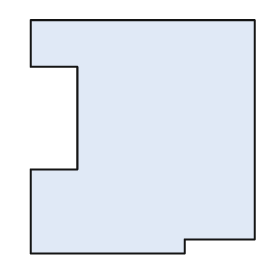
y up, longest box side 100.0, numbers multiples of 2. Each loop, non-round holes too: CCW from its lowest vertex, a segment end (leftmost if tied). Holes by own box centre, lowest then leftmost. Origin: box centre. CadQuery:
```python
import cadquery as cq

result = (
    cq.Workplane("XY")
    .moveTo(-48.0, -50.0)
    .lineTo(18.0, -50.0)
    .lineTo(18.0, -44.0)
    .lineTo(48.0, -44.0)
    .lineTo(48.0, 50.0)
    .lineTo(-48.0, 50.0)
    .lineTo(-48.0, 30.0)
    .lineTo(-28.0, 30.0)
    .lineTo(-28.0, -14.0)
    .lineTo(-48.0, -14.0)
    .close()
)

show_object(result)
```